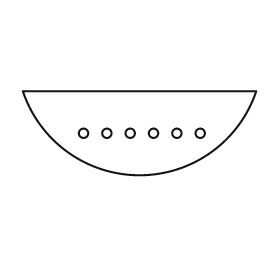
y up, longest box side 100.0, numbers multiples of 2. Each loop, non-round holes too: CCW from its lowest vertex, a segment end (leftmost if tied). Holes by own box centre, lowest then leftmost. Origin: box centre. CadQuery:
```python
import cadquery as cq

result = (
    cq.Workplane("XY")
    .moveTo(-50.0, 18.0)
    .threePointArc((0.0, -18.0), (50.0, 18.0))
    .close()
    .moveTo(-24.0, 0.0)
    .circle(2.0)
    .moveTo(-14.0, 0.0)
    .circle(2.0)
    .moveTo(-4.0, 0.0)
    .circle(2.0)
    .moveTo(6.0, 0.0)
    .circle(2.0)
    .moveTo(16.0, 0.0)
    .circle(2.0)
    .moveTo(26.0, 0.0)
    .circle(2.0)
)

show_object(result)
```